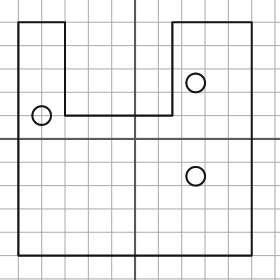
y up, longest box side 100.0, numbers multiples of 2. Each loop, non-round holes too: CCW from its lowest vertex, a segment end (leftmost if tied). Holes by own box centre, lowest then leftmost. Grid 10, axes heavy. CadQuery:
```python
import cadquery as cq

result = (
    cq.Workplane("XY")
    .moveTo(-50.0, -50.0)
    .lineTo(50.0, -50.0)
    .lineTo(50.0, 50.0)
    .lineTo(16.0, 50.0)
    .lineTo(16.0, 10.0)
    .lineTo(-30.0, 10.0)
    .lineTo(-30.0, 50.0)
    .lineTo(-50.0, 50.0)
    .close()
    .moveTo(26.0, -16.0)
    .circle(4.0)
    .moveTo(-40.0, 10.0)
    .circle(4.0)
    .moveTo(26.0, 24.0)
    .circle(4.0)
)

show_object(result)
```